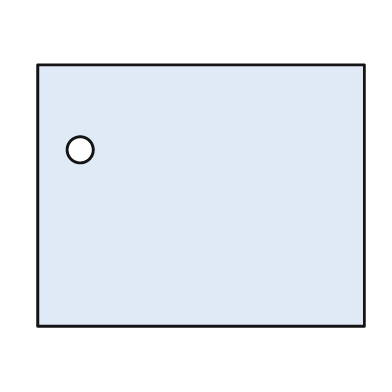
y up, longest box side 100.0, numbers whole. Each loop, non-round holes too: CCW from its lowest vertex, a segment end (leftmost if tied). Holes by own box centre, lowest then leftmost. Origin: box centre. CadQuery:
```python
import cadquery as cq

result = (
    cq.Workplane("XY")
    .moveTo(-50.0, -40.0)
    .lineTo(50.0, -40.0)
    .lineTo(50.0, 40.0)
    .lineTo(-50.0, 40.0)
    .close()
    .moveTo(-37.0, 14.0)
    .circle(4.0)
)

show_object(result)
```